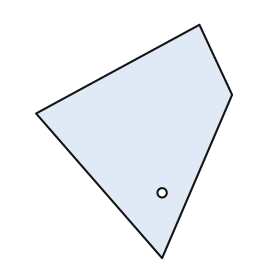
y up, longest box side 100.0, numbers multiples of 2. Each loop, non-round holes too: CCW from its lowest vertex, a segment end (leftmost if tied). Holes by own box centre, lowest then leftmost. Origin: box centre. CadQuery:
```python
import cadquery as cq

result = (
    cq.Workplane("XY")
    .moveTo(12.0, -50.0)
    .lineTo(42.0, 20.0)
    .lineTo(28.0, 50.0)
    .lineTo(-42.0, 12.0)
    .close()
    .moveTo(12.0, -22.0)
    .circle(2.0)
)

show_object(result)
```